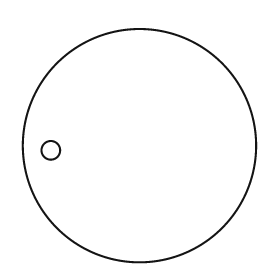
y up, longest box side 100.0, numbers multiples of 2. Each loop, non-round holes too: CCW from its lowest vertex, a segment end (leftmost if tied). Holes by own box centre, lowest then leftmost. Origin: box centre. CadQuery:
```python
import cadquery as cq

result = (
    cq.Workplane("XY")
    .moveTo(0.0, 0.0)
    .circle(50.0)
    .moveTo(-38.0, -2.0)
    .circle(4.0)
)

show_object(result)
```